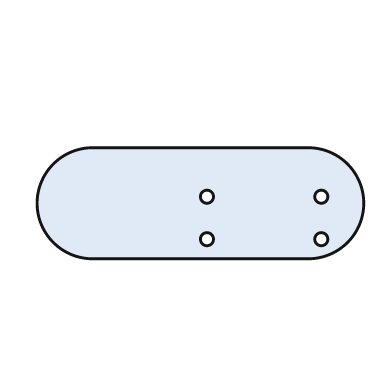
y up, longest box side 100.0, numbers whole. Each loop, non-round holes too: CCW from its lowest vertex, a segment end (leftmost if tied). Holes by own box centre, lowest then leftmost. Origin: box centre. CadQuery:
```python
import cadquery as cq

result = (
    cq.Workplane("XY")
    .moveTo(-33.0, -17.0)
    .lineTo(33.0, -17.0)
    .threePointArc((50.0, 0.0), (33.0, 17.0))
    .lineTo(-33.0, 17.0)
    .threePointArc((-50.0, 0.0), (-33.0, -17.0))
    .close()
    .moveTo(2.0, -11.0)
    .circle(2.0)
    .moveTo(37.0, -11.0)
    .circle(2.0)
    .moveTo(2.0, 2.0)
    .circle(2.0)
    .moveTo(37.0, 2.0)
    .circle(2.0)
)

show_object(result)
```